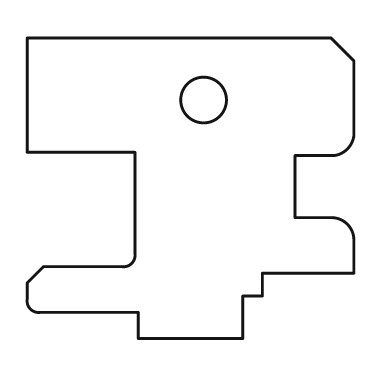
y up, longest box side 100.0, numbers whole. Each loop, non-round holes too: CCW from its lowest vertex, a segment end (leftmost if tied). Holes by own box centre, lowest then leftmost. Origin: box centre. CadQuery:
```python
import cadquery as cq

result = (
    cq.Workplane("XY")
    .moveTo(-16.0, -46.0)
    .lineTo(16.0, -46.0)
    .lineTo(16.0, -33.0)
    .lineTo(22.0, -33.0)
    .lineTo(22.0, -26.0)
    .lineTo(50.0, -26.0)
    .lineTo(50.0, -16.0)
    .threePointArc((48.0, -11.0), (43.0, -9.0))
    .lineTo(32.0, -9.0)
    .lineTo(32.0, 10.0)
    .lineTo(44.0, 10.0)
    .threePointArc((48.0, 12.0), (50.0, 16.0))
    .lineTo(50.0, 39.0)
    .lineTo(43.0, 46.0)
    .lineTo(-50.0, 46.0)
    .lineTo(-50.0, 11.0)
    .lineTo(-17.0, 11.0)
    .lineTo(-17.0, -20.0)
    .threePointArc((-18.0, -23.0), (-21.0, -24.0))
    .lineTo(-45.0, -24.0)
    .lineTo(-50.0, -29.0)
    .lineTo(-50.0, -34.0)
    .threePointArc((-49.0, -37.0), (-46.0, -38.0))
    .lineTo(-16.0, -38.0)
    .close()
    .moveTo(4.0, 27.0)
    .circle(7.0)
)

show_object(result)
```